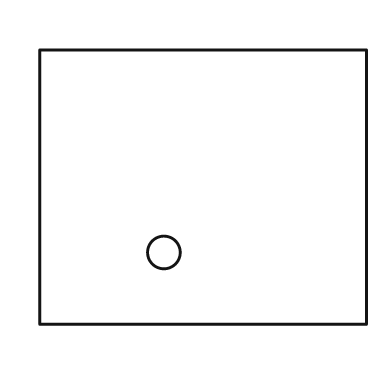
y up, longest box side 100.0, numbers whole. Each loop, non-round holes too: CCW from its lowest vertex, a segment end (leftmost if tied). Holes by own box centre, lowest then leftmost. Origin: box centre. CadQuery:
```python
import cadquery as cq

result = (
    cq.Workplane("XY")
    .moveTo(-50.0, -42.0)
    .lineTo(50.0, -42.0)
    .lineTo(50.0, 42.0)
    .lineTo(-50.0, 42.0)
    .close()
    .moveTo(-12.0, -20.0)
    .circle(5.0)
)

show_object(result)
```